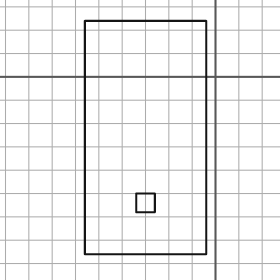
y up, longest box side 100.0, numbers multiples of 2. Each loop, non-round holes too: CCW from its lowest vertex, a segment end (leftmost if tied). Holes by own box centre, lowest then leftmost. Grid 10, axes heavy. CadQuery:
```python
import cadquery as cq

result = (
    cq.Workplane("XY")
    .moveTo(-56.0, -76.0)
    .lineTo(-4.0, -76.0)
    .lineTo(-4.0, 24.0)
    .lineTo(-56.0, 24.0)
    .close()
    .moveTo(-34.0, -58.0)
    .lineTo(-26.0, -58.0)
    .lineTo(-26.0, -50.0)
    .lineTo(-34.0, -50.0)
    .close()
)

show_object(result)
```